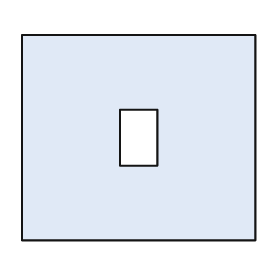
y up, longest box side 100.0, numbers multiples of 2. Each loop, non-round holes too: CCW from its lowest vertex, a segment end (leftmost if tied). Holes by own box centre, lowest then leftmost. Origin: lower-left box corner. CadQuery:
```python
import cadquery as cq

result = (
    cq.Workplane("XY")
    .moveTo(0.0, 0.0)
    .lineTo(100.0, 0.0)
    .lineTo(100.0, 88.0)
    .lineTo(0.0, 88.0)
    .close()
    .moveTo(42.0, 32.0)
    .lineTo(58.0, 32.0)
    .lineTo(58.0, 56.0)
    .lineTo(42.0, 56.0)
    .close()
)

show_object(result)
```